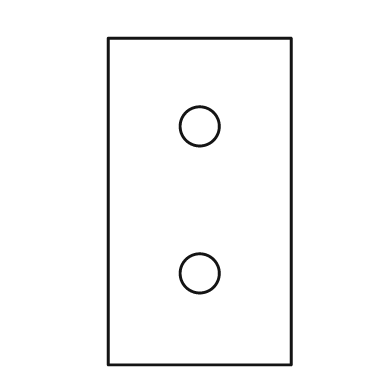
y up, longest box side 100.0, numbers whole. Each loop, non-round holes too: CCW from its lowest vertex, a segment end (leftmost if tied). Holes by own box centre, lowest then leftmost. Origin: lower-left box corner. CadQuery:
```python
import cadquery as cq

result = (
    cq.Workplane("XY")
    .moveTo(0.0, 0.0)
    .lineTo(56.0, 0.0)
    .lineTo(56.0, 100.0)
    .lineTo(0.0, 100.0)
    .close()
    .moveTo(28.0, 28.0)
    .circle(6.0)
    .moveTo(28.0, 73.0)
    .circle(6.0)
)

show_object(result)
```